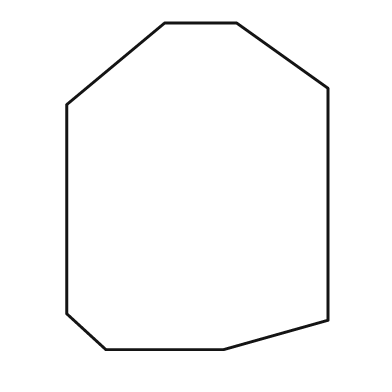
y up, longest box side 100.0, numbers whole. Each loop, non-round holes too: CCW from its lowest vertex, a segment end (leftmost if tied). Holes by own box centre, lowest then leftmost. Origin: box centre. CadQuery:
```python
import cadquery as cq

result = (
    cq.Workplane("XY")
    .moveTo(-28.0, -50.0)
    .lineTo(8.0, -50.0)
    .lineTo(40.0, -41.0)
    .lineTo(40.0, 30.0)
    .lineTo(12.0, 50.0)
    .lineTo(-10.0, 50.0)
    .lineTo(-40.0, 25.0)
    .lineTo(-40.0, -39.0)
    .close()
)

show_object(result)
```